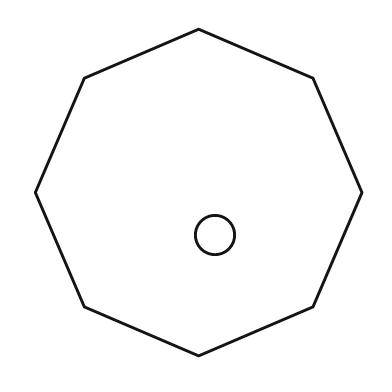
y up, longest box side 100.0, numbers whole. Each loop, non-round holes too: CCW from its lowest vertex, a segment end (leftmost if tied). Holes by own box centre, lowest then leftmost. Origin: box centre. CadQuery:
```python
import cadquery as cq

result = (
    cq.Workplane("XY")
    .moveTo(0.0, -50.0)
    .lineTo(35.0, -35.0)
    .lineTo(50.0, 0.0)
    .lineTo(35.0, 35.0)
    .lineTo(0.0, 50.0)
    .lineTo(-35.0, 35.0)
    .lineTo(-50.0, 0.0)
    .lineTo(-35.0, -35.0)
    .close()
    .moveTo(5.0, -13.0)
    .circle(6.0)
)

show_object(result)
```